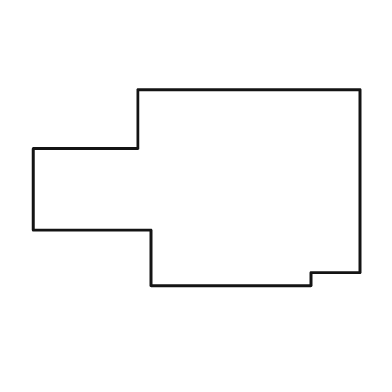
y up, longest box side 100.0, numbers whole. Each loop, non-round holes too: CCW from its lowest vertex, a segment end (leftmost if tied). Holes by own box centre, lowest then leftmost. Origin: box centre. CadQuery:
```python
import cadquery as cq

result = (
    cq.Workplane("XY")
    .moveTo(-14.0, -30.0)
    .lineTo(35.0, -30.0)
    .lineTo(35.0, -26.0)
    .lineTo(50.0, -26.0)
    .lineTo(50.0, 30.0)
    .lineTo(-18.0, 30.0)
    .lineTo(-18.0, 12.0)
    .lineTo(-50.0, 12.0)
    .lineTo(-50.0, -13.0)
    .lineTo(-14.0, -13.0)
    .close()
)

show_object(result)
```